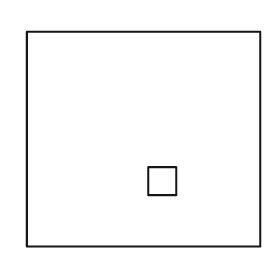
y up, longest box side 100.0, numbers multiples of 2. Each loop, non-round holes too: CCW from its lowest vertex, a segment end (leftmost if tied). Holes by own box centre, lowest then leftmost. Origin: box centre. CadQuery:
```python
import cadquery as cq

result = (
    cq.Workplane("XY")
    .moveTo(-50.0, -46.0)
    .lineTo(50.0, -46.0)
    .lineTo(50.0, 46.0)
    .lineTo(-50.0, 46.0)
    .close()
    .moveTo(2.0, -24.0)
    .lineTo(14.0, -24.0)
    .lineTo(14.0, -12.0)
    .lineTo(2.0, -12.0)
    .close()
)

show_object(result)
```